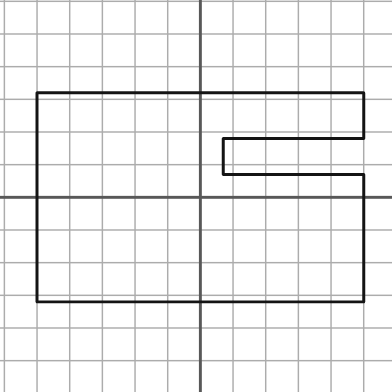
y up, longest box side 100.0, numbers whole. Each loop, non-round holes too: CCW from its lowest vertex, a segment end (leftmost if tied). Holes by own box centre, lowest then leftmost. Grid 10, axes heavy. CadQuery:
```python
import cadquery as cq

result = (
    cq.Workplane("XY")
    .moveTo(-50.0, -32.0)
    .lineTo(50.0, -32.0)
    .lineTo(50.0, 7.0)
    .lineTo(7.0, 7.0)
    .lineTo(7.0, 18.0)
    .lineTo(50.0, 18.0)
    .lineTo(50.0, 32.0)
    .lineTo(-50.0, 32.0)
    .close()
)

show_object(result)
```